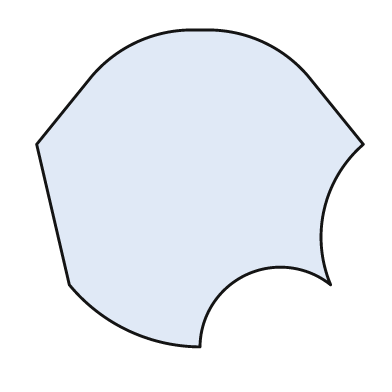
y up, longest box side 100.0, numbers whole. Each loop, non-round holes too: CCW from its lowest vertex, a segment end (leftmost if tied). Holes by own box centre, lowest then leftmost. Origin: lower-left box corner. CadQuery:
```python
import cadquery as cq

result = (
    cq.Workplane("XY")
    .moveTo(50.0, 0.0)
    .threePointArc((64.0, 22.0), (90.0, 19.0))
    .threePointArc((88.0, 42.0), (100.0, 62.0))
    .lineTo(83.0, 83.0)
    .threePointArc((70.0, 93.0), (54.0, 97.0))
    .lineTo(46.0, 97.0)
    .threePointArc((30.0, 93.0), (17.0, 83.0))
    .lineTo(0.0, 62.0)
    .lineTo(10.0, 19.0)
    .threePointArc((28.0, 5.0), (50.0, 0.0))
    .close()
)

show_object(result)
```